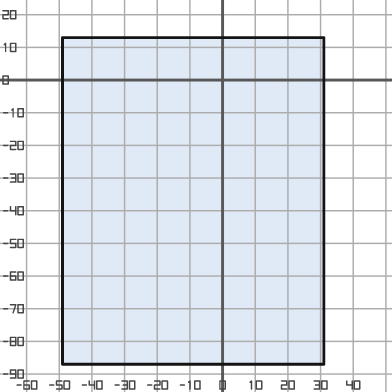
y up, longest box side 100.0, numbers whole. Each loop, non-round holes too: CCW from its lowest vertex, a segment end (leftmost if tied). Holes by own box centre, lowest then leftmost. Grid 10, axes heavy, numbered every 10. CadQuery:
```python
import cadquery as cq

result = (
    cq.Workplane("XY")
    .moveTo(-49.0, -87.0)
    .lineTo(31.0, -87.0)
    .lineTo(31.0, 13.0)
    .lineTo(-49.0, 13.0)
    .close()
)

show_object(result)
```